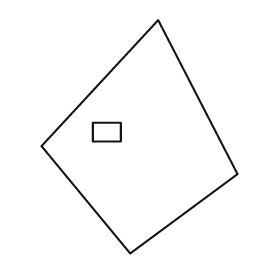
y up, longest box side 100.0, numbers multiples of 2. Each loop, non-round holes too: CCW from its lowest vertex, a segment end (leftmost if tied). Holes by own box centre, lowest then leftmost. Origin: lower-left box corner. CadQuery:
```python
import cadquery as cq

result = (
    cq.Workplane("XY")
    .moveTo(38.0, 0.0)
    .lineTo(84.0, 34.0)
    .lineTo(50.0, 100.0)
    .lineTo(0.0, 46.0)
    .close()
    .moveTo(22.0, 48.0)
    .lineTo(34.0, 48.0)
    .lineTo(34.0, 56.0)
    .lineTo(22.0, 56.0)
    .close()
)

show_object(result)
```